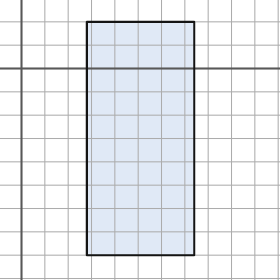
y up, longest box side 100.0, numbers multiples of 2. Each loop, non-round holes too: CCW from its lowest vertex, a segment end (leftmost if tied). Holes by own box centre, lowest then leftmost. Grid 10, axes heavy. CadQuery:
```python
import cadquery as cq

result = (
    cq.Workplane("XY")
    .moveTo(28.0, -80.0)
    .lineTo(74.0, -80.0)
    .lineTo(74.0, 20.0)
    .lineTo(28.0, 20.0)
    .close()
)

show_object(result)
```